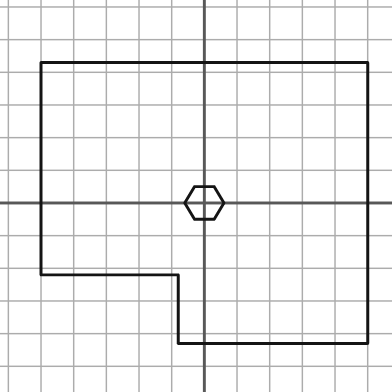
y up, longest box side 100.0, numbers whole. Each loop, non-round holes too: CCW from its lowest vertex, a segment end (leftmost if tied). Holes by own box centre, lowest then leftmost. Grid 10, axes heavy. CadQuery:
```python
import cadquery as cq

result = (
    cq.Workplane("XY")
    .moveTo(-8.0, -43.0)
    .lineTo(50.0, -43.0)
    .lineTo(50.0, 43.0)
    .lineTo(-50.0, 43.0)
    .lineTo(-50.0, -22.0)
    .lineTo(-8.0, -22.0)
    .close()
    .moveTo(-3.0, -5.0)
    .lineTo(3.0, -5.0)
    .lineTo(6.0, 0.0)
    .lineTo(3.0, 5.0)
    .lineTo(-3.0, 5.0)
    .lineTo(-6.0, 0.0)
    .close()
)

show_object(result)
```